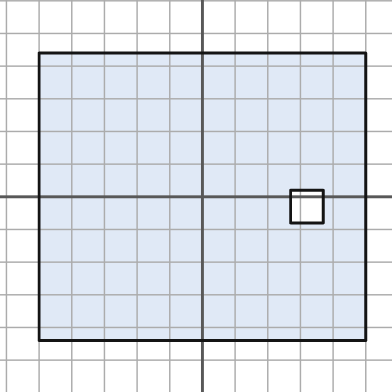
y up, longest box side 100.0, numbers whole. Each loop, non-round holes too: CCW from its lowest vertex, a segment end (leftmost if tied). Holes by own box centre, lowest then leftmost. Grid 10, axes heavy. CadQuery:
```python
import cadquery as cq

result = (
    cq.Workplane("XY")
    .moveTo(-50.0, -44.0)
    .lineTo(50.0, -44.0)
    .lineTo(50.0, 44.0)
    .lineTo(-50.0, 44.0)
    .close()
    .moveTo(27.0, -8.0)
    .lineTo(37.0, -8.0)
    .lineTo(37.0, 2.0)
    .lineTo(27.0, 2.0)
    .close()
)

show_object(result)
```